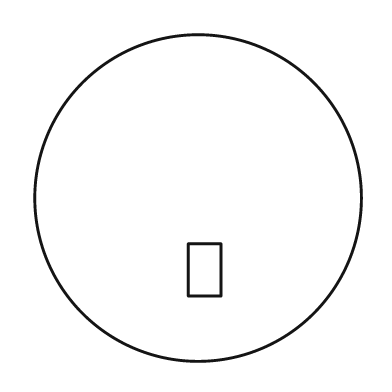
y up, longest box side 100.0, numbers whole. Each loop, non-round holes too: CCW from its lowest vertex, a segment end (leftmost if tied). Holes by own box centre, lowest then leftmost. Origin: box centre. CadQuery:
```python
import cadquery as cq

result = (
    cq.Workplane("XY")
    .moveTo(0.0, 0.0)
    .circle(50.0)
    .moveTo(-3.0, -30.0)
    .lineTo(7.0, -30.0)
    .lineTo(7.0, -14.0)
    .lineTo(-3.0, -14.0)
    .close()
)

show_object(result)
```